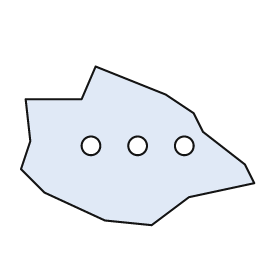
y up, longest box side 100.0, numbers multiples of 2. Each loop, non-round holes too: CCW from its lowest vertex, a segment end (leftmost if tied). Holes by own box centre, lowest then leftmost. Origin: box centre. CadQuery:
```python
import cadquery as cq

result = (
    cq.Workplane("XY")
    .moveTo(6.0, -34.0)
    .lineTo(22.0, -22.0)
    .lineTo(50.0, -16.0)
    .lineTo(46.0, -8.0)
    .lineTo(28.0, 6.0)
    .lineTo(24.0, 14.0)
    .lineTo(12.0, 22.0)
    .lineTo(-18.0, 34.0)
    .lineTo(-24.0, 20.0)
    .lineTo(-48.0, 20.0)
    .lineTo(-46.0, 2.0)
    .lineTo(-50.0, -10.0)
    .lineTo(-40.0, -20.0)
    .lineTo(-14.0, -32.0)
    .close()
    .moveTo(-20.0, 0.0)
    .circle(4.0)
    .moveTo(0.0, 0.0)
    .circle(4.0)
    .moveTo(20.0, 0.0)
    .circle(4.0)
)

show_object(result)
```